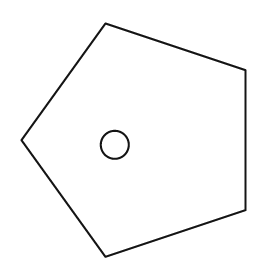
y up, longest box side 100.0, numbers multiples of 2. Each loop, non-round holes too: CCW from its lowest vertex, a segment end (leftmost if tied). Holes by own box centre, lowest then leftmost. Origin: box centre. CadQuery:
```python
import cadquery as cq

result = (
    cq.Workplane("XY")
    .moveTo(-12.0, -50.0)
    .lineTo(48.0, -30.0)
    .lineTo(48.0, 30.0)
    .lineTo(-12.0, 50.0)
    .lineTo(-48.0, 0.0)
    .close()
    .moveTo(-8.0, -2.0)
    .circle(6.0)
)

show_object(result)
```